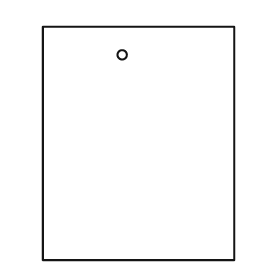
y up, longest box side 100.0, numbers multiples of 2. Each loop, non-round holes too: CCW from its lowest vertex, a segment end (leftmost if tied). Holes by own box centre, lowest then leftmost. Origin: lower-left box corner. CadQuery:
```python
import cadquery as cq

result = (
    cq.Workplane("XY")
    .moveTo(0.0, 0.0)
    .lineTo(82.0, 0.0)
    .lineTo(82.0, 100.0)
    .lineTo(0.0, 100.0)
    .close()
    .moveTo(34.0, 88.0)
    .circle(2.0)
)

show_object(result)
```